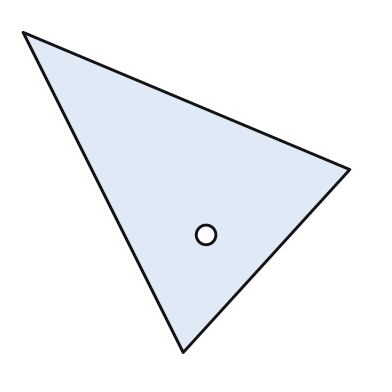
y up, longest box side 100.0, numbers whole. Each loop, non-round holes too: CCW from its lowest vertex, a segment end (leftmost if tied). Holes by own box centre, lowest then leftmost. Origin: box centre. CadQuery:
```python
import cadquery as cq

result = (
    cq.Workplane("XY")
    .moveTo(-1.0, -49.0)
    .lineTo(50.0, 7.0)
    .lineTo(-50.0, 49.0)
    .close()
    .moveTo(6.0, -13.0)
    .circle(3.0)
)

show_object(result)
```